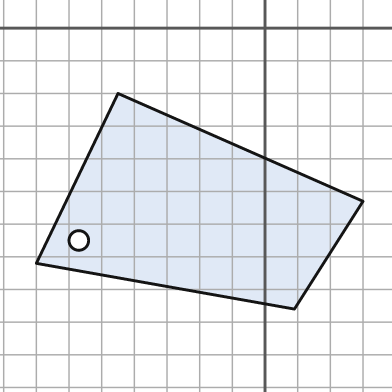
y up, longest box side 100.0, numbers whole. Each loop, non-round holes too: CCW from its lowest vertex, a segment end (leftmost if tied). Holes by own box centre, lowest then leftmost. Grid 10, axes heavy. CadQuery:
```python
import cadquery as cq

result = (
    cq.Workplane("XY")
    .moveTo(9.0, -86.0)
    .lineTo(30.0, -53.0)
    .lineTo(-45.0, -20.0)
    .lineTo(-70.0, -72.0)
    .close()
    .moveTo(-57.0, -65.0)
    .circle(3.0)
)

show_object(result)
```